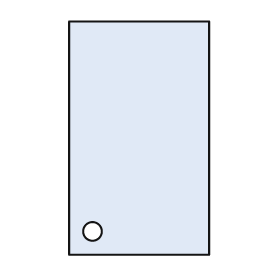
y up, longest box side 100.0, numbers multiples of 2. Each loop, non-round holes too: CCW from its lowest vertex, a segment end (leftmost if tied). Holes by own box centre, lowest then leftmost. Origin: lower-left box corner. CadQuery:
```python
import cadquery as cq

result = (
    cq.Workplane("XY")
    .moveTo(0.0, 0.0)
    .lineTo(60.0, 0.0)
    .lineTo(60.0, 100.0)
    .lineTo(0.0, 100.0)
    .close()
    .moveTo(10.0, 10.0)
    .circle(4.0)
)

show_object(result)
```